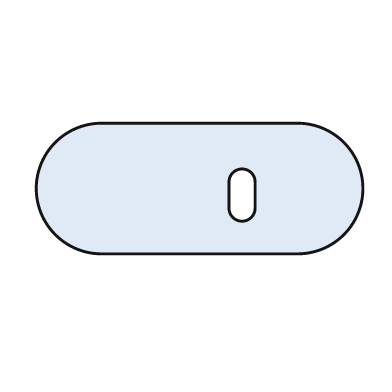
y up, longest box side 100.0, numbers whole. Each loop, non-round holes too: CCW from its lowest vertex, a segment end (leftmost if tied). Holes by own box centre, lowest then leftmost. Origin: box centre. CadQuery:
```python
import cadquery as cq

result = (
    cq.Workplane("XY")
    .moveTo(-30.0, -20.0)
    .lineTo(30.0, -20.0)
    .threePointArc((50.0, 0.0), (30.0, 20.0))
    .lineTo(-30.0, 20.0)
    .threePointArc((-50.0, 0.0), (-30.0, -20.0))
    .close()
    .moveTo(9.0, -6.0)
    .threePointArc((13.0, -10.0), (17.0, -6.0))
    .lineTo(17.0, 2.0)
    .threePointArc((13.0, 6.0), (9.0, 2.0))
    .close()
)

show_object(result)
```